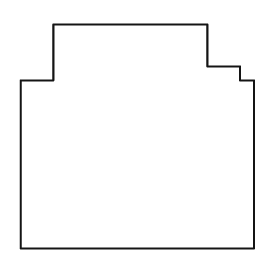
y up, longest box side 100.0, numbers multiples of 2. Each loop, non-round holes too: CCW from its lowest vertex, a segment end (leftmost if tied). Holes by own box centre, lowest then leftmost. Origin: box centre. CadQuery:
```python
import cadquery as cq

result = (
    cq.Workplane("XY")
    .moveTo(-50.0, -48.0)
    .lineTo(50.0, -48.0)
    .lineTo(50.0, 24.0)
    .lineTo(44.0, 24.0)
    .lineTo(44.0, 30.0)
    .lineTo(30.0, 30.0)
    .lineTo(30.0, 48.0)
    .lineTo(-36.0, 48.0)
    .lineTo(-36.0, 24.0)
    .lineTo(-50.0, 24.0)
    .close()
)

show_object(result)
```